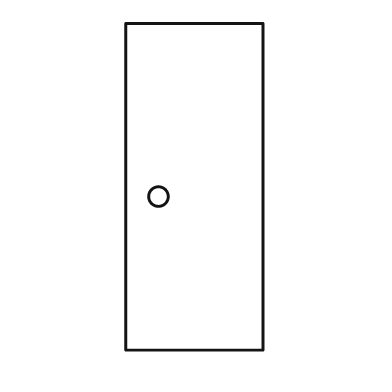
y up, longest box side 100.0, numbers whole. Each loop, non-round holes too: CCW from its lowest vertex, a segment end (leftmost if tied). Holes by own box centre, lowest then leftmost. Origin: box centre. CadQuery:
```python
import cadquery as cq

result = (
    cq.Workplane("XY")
    .moveTo(-21.0, -50.0)
    .lineTo(21.0, -50.0)
    .lineTo(21.0, 50.0)
    .lineTo(-21.0, 50.0)
    .close()
    .moveTo(-11.0, -3.0)
    .circle(3.0)
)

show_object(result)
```